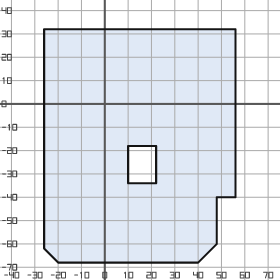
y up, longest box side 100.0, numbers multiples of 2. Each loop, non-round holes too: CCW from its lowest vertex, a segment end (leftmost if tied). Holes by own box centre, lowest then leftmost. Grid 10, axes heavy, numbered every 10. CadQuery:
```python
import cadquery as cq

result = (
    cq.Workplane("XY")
    .moveTo(-20.0, -68.0)
    .lineTo(40.0, -68.0)
    .lineTo(48.0, -60.0)
    .lineTo(48.0, -40.0)
    .lineTo(56.0, -40.0)
    .lineTo(56.0, 32.0)
    .lineTo(-26.0, 32.0)
    .lineTo(-26.0, -62.0)
    .close()
    .moveTo(10.0, -34.0)
    .lineTo(22.0, -34.0)
    .lineTo(22.0, -18.0)
    .lineTo(10.0, -18.0)
    .close()
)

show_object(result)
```